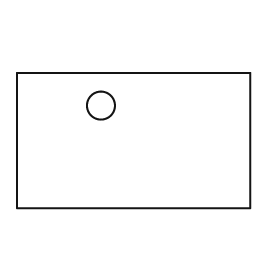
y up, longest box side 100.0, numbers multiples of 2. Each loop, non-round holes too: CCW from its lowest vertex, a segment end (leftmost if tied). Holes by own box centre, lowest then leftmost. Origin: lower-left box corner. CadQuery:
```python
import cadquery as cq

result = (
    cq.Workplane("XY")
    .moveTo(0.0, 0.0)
    .lineTo(100.0, 0.0)
    .lineTo(100.0, 58.0)
    .lineTo(0.0, 58.0)
    .close()
    .moveTo(36.0, 44.0)
    .circle(6.0)
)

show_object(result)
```